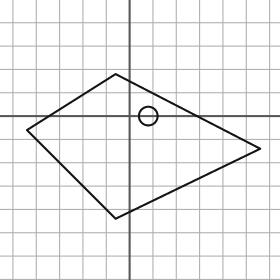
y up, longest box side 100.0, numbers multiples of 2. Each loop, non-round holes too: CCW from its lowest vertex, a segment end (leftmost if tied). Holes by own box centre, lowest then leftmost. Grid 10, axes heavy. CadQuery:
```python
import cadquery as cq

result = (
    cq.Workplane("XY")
    .moveTo(-6.0, -44.0)
    .lineTo(56.0, -14.0)
    .lineTo(-6.0, 18.0)
    .lineTo(-44.0, -6.0)
    .close()
    .moveTo(8.0, 0.0)
    .circle(4.0)
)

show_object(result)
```